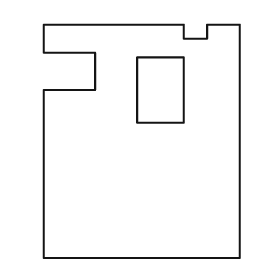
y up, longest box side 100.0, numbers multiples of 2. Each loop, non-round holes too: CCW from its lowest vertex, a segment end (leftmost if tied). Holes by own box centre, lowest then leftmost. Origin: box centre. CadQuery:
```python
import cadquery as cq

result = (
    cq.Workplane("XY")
    .moveTo(-42.0, -50.0)
    .lineTo(42.0, -50.0)
    .lineTo(42.0, 50.0)
    .lineTo(28.0, 50.0)
    .lineTo(28.0, 44.0)
    .lineTo(18.0, 44.0)
    .lineTo(18.0, 50.0)
    .lineTo(-42.0, 50.0)
    .lineTo(-42.0, 38.0)
    .lineTo(-20.0, 38.0)
    .lineTo(-20.0, 22.0)
    .lineTo(-42.0, 22.0)
    .close()
    .moveTo(-2.0, 8.0)
    .lineTo(18.0, 8.0)
    .lineTo(18.0, 36.0)
    .lineTo(-2.0, 36.0)
    .close()
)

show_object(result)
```